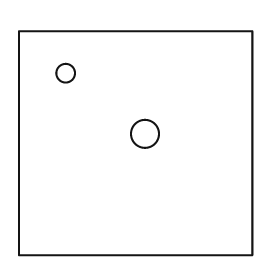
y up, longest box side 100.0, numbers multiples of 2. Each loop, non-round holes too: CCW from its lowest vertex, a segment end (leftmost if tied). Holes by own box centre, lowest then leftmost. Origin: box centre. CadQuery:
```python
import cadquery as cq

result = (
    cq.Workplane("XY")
    .moveTo(-50.0, -48.0)
    .lineTo(50.0, -48.0)
    .lineTo(50.0, 48.0)
    .lineTo(-50.0, 48.0)
    .close()
    .moveTo(4.0, 4.0)
    .circle(6.0)
    .moveTo(-30.0, 30.0)
    .circle(4.0)
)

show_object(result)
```